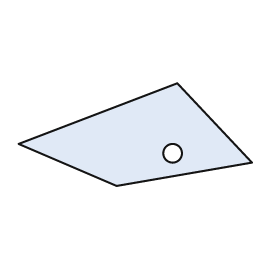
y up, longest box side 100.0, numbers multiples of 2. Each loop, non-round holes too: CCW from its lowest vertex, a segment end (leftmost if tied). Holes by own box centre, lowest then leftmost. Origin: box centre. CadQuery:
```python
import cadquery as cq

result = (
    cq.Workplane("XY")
    .moveTo(-8.0, -22.0)
    .lineTo(50.0, -12.0)
    .lineTo(18.0, 22.0)
    .lineTo(-50.0, -4.0)
    .close()
    .moveTo(16.0, -8.0)
    .circle(4.0)
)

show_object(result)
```